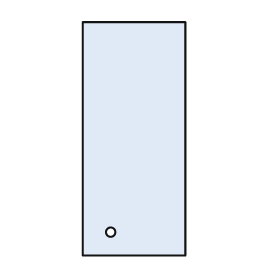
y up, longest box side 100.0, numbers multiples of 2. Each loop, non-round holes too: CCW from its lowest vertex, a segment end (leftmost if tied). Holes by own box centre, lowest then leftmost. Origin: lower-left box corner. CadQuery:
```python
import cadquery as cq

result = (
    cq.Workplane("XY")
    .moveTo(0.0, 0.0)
    .lineTo(44.0, 0.0)
    .lineTo(44.0, 100.0)
    .lineTo(0.0, 100.0)
    .close()
    .moveTo(12.0, 10.0)
    .circle(2.0)
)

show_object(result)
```